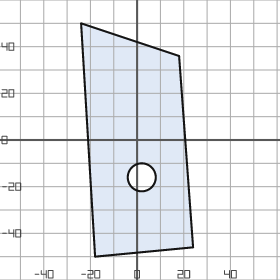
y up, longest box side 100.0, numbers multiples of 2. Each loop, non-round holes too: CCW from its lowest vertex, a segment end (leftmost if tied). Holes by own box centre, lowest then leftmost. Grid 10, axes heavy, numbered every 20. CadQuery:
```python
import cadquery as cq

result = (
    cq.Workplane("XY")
    .moveTo(-18.0, -50.0)
    .lineTo(24.0, -46.0)
    .lineTo(18.0, 36.0)
    .lineTo(-24.0, 50.0)
    .close()
    .moveTo(2.0, -16.0)
    .circle(6.0)
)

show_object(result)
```